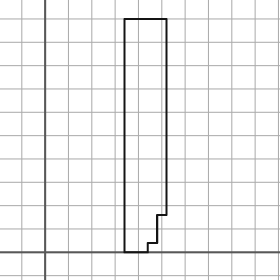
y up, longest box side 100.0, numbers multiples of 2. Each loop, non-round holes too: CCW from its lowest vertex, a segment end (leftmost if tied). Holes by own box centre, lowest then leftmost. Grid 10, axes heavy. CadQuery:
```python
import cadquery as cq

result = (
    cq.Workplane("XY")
    .moveTo(34.0, 0.0)
    .lineTo(44.0, 0.0)
    .lineTo(44.0, 4.0)
    .lineTo(48.0, 4.0)
    .lineTo(48.0, 16.0)
    .lineTo(52.0, 16.0)
    .lineTo(52.0, 100.0)
    .lineTo(34.0, 100.0)
    .close()
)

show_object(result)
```